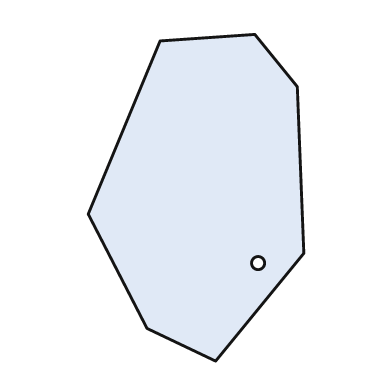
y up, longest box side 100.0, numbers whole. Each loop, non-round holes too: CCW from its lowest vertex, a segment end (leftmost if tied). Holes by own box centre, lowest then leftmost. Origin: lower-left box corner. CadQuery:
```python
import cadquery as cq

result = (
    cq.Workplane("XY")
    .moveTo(39.0, 0.0)
    .lineTo(66.0, 33.0)
    .lineTo(64.0, 84.0)
    .lineTo(51.0, 100.0)
    .lineTo(22.0, 98.0)
    .lineTo(0.0, 45.0)
    .lineTo(18.0, 10.0)
    .close()
    .moveTo(52.0, 30.0)
    .circle(2.0)
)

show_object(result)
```